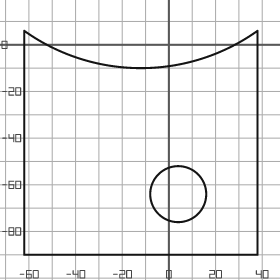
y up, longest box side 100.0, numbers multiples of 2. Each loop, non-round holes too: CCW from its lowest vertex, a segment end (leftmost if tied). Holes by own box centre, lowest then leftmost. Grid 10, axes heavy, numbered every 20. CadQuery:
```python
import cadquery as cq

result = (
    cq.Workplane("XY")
    .moveTo(-62.0, -90.0)
    .lineTo(38.0, -90.0)
    .lineTo(38.0, 6.0)
    .threePointArc((-12.0, -10.0), (-62.0, 6.0))
    .close()
    .moveTo(4.0, -64.0)
    .circle(12.0)
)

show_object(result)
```